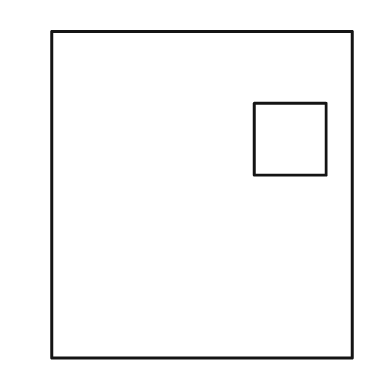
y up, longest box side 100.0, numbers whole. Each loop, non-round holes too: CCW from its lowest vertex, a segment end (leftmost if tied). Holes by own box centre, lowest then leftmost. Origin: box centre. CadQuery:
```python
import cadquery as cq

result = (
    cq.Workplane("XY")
    .moveTo(-46.0, -50.0)
    .lineTo(46.0, -50.0)
    .lineTo(46.0, 50.0)
    .lineTo(-46.0, 50.0)
    .close()
    .moveTo(16.0, 6.0)
    .lineTo(38.0, 6.0)
    .lineTo(38.0, 28.0)
    .lineTo(16.0, 28.0)
    .close()
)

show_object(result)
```